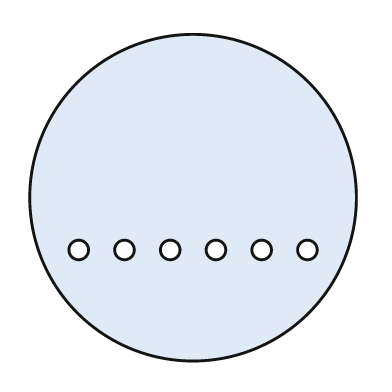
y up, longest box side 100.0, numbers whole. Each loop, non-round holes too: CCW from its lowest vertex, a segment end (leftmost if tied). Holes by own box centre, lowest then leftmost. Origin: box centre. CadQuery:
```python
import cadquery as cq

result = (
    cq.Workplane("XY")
    .moveTo(0.0, 0.0)
    .circle(50.0)
    .moveTo(-35.0, -16.0)
    .circle(3.0)
    .moveTo(-21.0, -16.0)
    .circle(3.0)
    .moveTo(-7.0, -16.0)
    .circle(3.0)
    .moveTo(7.0, -16.0)
    .circle(3.0)
    .moveTo(21.0, -16.0)
    .circle(3.0)
    .moveTo(35.0, -16.0)
    .circle(3.0)
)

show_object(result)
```